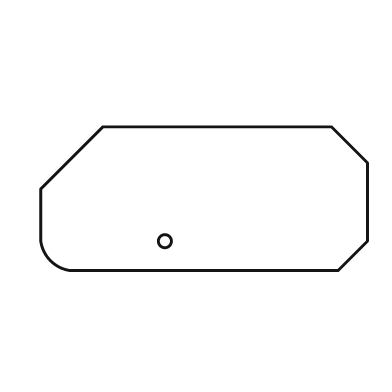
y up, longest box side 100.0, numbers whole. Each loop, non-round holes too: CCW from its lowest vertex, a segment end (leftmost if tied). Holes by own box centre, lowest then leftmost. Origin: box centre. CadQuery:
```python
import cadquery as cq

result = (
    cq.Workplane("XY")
    .moveTo(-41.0, -22.0)
    .lineTo(41.0, -22.0)
    .lineTo(50.0, -13.0)
    .lineTo(50.0, 11.0)
    .lineTo(39.0, 22.0)
    .lineTo(-31.0, 22.0)
    .lineTo(-50.0, 3.0)
    .lineTo(-50.0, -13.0)
    .threePointArc((-47.0, -19.0), (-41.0, -22.0))
    .close()
    .moveTo(-12.0, -13.0)
    .circle(2.0)
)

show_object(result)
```